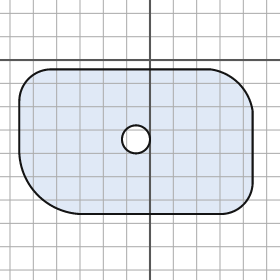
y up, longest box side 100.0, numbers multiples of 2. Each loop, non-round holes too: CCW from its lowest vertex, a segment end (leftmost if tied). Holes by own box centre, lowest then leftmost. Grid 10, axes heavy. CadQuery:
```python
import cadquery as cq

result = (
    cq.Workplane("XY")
    .moveTo(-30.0, -66.0)
    .lineTo(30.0, -66.0)
    .threePointArc((40.0, -62.0), (44.0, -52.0))
    .lineTo(44.0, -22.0)
    .threePointArc((38.0, -10.0), (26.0, -4.0))
    .lineTo(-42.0, -4.0)
    .threePointArc((-52.0, -8.0), (-56.0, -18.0))
    .lineTo(-56.0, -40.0)
    .threePointArc((-48.0, -58.0), (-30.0, -66.0))
    .close()
    .moveTo(-6.0, -34.0)
    .circle(6.0)
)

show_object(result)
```